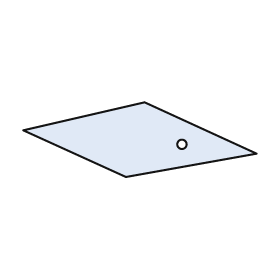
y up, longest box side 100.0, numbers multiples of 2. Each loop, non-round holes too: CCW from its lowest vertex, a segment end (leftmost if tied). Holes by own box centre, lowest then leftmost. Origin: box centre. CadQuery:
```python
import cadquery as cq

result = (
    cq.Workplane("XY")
    .moveTo(-6.0, -16.0)
    .lineTo(50.0, -6.0)
    .lineTo(2.0, 16.0)
    .lineTo(-50.0, 4.0)
    .close()
    .moveTo(18.0, -2.0)
    .circle(2.0)
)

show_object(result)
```